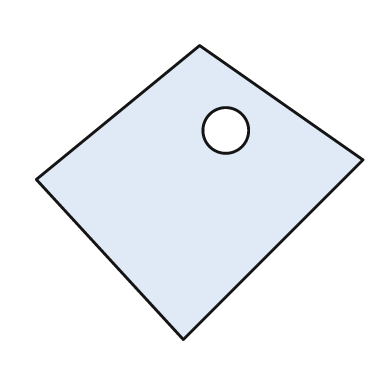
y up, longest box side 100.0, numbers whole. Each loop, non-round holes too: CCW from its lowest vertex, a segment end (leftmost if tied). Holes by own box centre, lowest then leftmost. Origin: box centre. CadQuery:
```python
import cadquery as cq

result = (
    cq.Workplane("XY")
    .moveTo(-5.0, -45.0)
    .lineTo(50.0, 10.0)
    .lineTo(0.0, 45.0)
    .lineTo(-50.0, 4.0)
    .close()
    .moveTo(8.0, 19.0)
    .circle(7.0)
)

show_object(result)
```